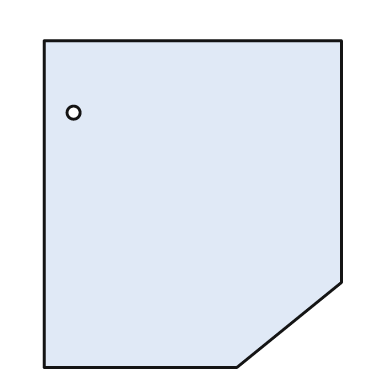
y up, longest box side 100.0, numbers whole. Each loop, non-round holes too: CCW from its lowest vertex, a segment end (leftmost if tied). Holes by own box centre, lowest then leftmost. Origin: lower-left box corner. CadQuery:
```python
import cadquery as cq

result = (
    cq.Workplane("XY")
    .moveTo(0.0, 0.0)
    .lineTo(59.0, 0.0)
    .lineTo(91.0, 26.0)
    .lineTo(91.0, 100.0)
    .lineTo(0.0, 100.0)
    .close()
    .moveTo(9.0, 78.0)
    .circle(2.0)
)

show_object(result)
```